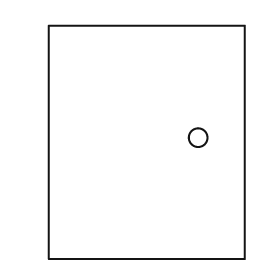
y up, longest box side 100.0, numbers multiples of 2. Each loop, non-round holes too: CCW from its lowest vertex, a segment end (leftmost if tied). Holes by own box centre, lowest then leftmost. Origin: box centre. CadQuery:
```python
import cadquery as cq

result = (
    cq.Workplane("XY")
    .moveTo(-42.0, -50.0)
    .lineTo(42.0, -50.0)
    .lineTo(42.0, 50.0)
    .lineTo(-42.0, 50.0)
    .close()
    .moveTo(22.0, 2.0)
    .circle(4.0)
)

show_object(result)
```